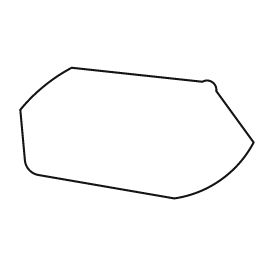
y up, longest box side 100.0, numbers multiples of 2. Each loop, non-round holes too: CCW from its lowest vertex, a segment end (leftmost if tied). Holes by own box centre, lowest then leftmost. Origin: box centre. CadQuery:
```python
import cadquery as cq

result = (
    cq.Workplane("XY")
    .moveTo(16.0, -28.0)
    .threePointArc((36.0, -20.0), (50.0, -4.0))
    .lineTo(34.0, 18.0)
    .threePointArc((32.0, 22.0), (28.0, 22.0))
    .lineTo(-28.0, 28.0)
    .threePointArc((-40.0, 20.0), (-50.0, 10.0))
    .lineTo(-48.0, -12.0)
    .threePointArc((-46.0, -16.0), (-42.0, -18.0))
    .close()
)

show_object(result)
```